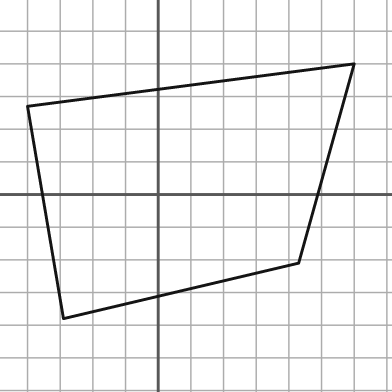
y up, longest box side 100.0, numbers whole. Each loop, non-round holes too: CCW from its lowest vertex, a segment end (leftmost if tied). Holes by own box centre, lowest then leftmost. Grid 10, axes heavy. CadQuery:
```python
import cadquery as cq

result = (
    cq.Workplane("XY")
    .moveTo(-29.0, -38.0)
    .lineTo(43.0, -21.0)
    .lineTo(60.0, 40.0)
    .lineTo(-40.0, 27.0)
    .close()
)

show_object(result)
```